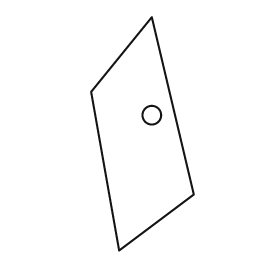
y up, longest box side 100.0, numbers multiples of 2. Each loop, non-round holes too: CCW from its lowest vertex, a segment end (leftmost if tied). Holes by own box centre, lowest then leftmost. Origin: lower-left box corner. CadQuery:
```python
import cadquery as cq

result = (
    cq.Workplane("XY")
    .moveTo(12.0, 0.0)
    .lineTo(44.0, 24.0)
    .lineTo(26.0, 100.0)
    .lineTo(0.0, 68.0)
    .close()
    .moveTo(26.0, 58.0)
    .circle(4.0)
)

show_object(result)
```